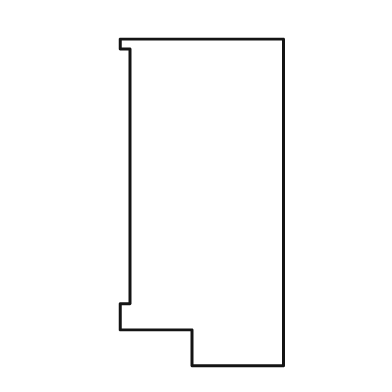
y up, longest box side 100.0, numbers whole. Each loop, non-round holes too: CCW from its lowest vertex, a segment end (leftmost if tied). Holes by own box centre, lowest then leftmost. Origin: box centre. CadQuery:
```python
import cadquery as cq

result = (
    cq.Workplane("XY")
    .moveTo(-3.0, -50.0)
    .lineTo(25.0, -50.0)
    .lineTo(25.0, 50.0)
    .lineTo(-25.0, 50.0)
    .lineTo(-25.0, 47.0)
    .lineTo(-22.0, 47.0)
    .lineTo(-22.0, -31.0)
    .lineTo(-25.0, -31.0)
    .lineTo(-25.0, -39.0)
    .lineTo(-3.0, -39.0)
    .close()
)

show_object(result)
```